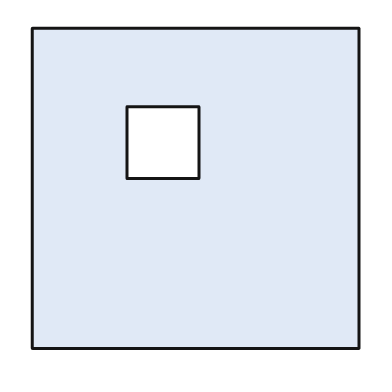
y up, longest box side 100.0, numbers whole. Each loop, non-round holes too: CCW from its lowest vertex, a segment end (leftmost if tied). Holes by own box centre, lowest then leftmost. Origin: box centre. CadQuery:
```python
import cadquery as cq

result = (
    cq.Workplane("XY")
    .moveTo(-50.0, -49.0)
    .lineTo(50.0, -49.0)
    .lineTo(50.0, 49.0)
    .lineTo(-50.0, 49.0)
    .close()
    .moveTo(-21.0, 3.0)
    .lineTo(1.0, 3.0)
    .lineTo(1.0, 25.0)
    .lineTo(-21.0, 25.0)
    .close()
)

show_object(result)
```